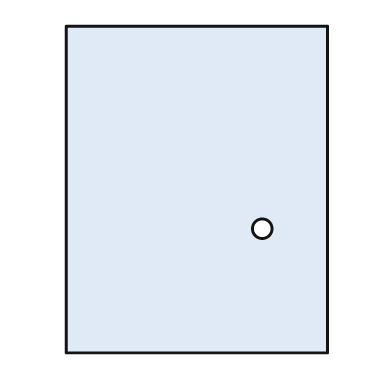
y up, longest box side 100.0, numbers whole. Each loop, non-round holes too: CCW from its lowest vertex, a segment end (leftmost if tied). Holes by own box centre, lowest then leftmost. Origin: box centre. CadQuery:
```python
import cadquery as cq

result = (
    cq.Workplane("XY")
    .moveTo(-40.0, -50.0)
    .lineTo(40.0, -50.0)
    .lineTo(40.0, 50.0)
    .lineTo(-40.0, 50.0)
    .close()
    .moveTo(20.0, -12.0)
    .circle(3.0)
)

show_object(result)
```